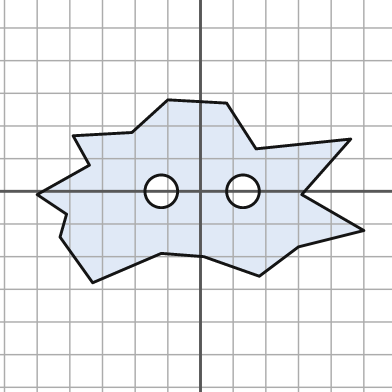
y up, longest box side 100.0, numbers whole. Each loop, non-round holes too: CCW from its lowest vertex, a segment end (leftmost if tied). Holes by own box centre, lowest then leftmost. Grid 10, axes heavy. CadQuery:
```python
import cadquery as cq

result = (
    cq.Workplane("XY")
    .moveTo(-33.0, -28.0)
    .lineTo(-12.0, -19.0)
    .lineTo(1.0, -20.0)
    .lineTo(18.0, -26.0)
    .lineTo(30.0, -17.0)
    .lineTo(50.0, -12.0)
    .lineTo(31.0, -1.0)
    .lineTo(46.0, 16.0)
    .lineTo(17.0, 13.0)
    .lineTo(8.0, 27.0)
    .lineTo(-10.0, 28.0)
    .lineTo(-21.0, 18.0)
    .lineTo(-39.0, 17.0)
    .lineTo(-34.0, 8.0)
    .lineTo(-50.0, -1.0)
    .lineTo(-41.0, -7.0)
    .lineTo(-43.0, -14.0)
    .close()
    .moveTo(-12.0, 0.0)
    .circle(5.0)
    .moveTo(13.0, 0.0)
    .circle(5.0)
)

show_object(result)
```